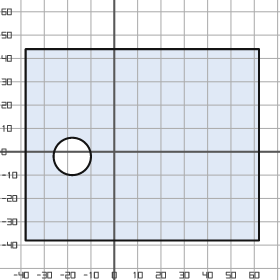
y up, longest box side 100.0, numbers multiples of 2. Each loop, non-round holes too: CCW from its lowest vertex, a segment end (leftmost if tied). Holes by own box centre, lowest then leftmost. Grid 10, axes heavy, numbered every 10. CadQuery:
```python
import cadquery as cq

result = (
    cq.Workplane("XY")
    .moveTo(-38.0, -38.0)
    .lineTo(62.0, -38.0)
    .lineTo(62.0, 44.0)
    .lineTo(-38.0, 44.0)
    .close()
    .moveTo(-18.0, -2.0)
    .circle(8.0)
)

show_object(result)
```